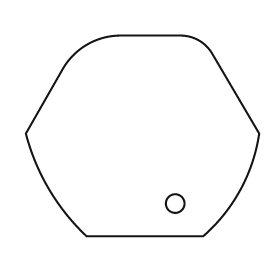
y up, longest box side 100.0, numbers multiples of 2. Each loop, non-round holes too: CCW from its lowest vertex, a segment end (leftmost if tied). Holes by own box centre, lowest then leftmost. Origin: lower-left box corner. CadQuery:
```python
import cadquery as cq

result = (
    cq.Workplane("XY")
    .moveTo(26.0, 0.0)
    .lineTo(76.0, 0.0)
    .threePointArc((92.0, 20.0), (100.0, 44.0))
    .lineTo(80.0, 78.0)
    .threePointArc((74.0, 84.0), (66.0, 86.0))
    .lineTo(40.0, 86.0)
    .threePointArc((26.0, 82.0), (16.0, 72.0))
    .lineTo(0.0, 44.0)
    .threePointArc((10.0, 20.0), (26.0, 0.0))
    .close()
    .moveTo(64.0, 14.0)
    .circle(4.0)
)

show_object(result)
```